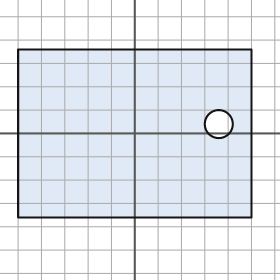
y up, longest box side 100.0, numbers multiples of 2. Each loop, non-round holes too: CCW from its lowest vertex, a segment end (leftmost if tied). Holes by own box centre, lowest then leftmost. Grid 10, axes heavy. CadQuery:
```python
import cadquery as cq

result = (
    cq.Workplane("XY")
    .moveTo(-50.0, -36.0)
    .lineTo(50.0, -36.0)
    .lineTo(50.0, 36.0)
    .lineTo(-50.0, 36.0)
    .close()
    .moveTo(36.0, 4.0)
    .circle(6.0)
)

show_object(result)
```